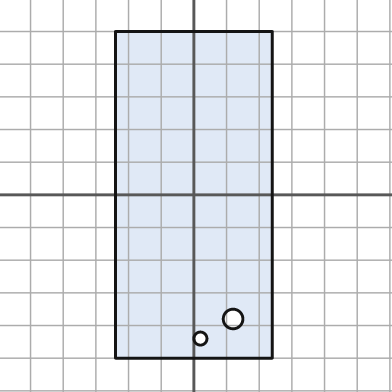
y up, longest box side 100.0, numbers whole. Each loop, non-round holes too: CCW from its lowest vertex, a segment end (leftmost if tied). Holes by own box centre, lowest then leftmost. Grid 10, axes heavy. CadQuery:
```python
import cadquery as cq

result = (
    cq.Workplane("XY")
    .moveTo(-24.0, -50.0)
    .lineTo(24.0, -50.0)
    .lineTo(24.0, 50.0)
    .lineTo(-24.0, 50.0)
    .close()
    .moveTo(2.0, -44.0)
    .circle(2.0)
    .moveTo(12.0, -38.0)
    .circle(3.0)
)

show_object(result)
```